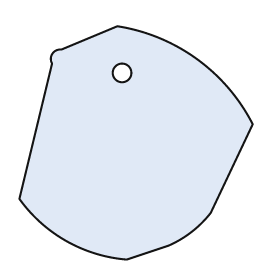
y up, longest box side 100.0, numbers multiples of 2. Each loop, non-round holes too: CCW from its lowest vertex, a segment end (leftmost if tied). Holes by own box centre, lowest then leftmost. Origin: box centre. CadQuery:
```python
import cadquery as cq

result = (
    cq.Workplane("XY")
    .moveTo(-4.0, -50.0)
    .lineTo(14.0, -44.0)
    .threePointArc((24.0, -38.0), (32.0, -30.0))
    .lineTo(50.0, 8.0)
    .threePointArc((26.0, 36.0), (-8.0, 50.0))
    .lineTo(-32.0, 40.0)
    .threePointArc((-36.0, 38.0), (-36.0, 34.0))
    .lineTo(-50.0, -24.0)
    .threePointArc((-30.0, -42.0), (-4.0, -50.0))
    .close()
    .moveTo(-6.0, 30.0)
    .circle(4.0)
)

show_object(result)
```